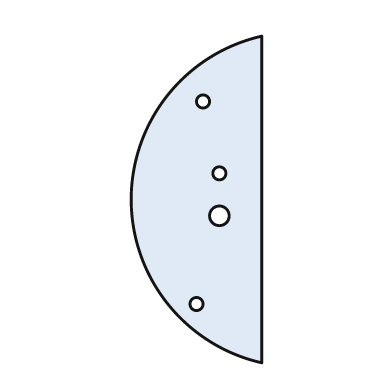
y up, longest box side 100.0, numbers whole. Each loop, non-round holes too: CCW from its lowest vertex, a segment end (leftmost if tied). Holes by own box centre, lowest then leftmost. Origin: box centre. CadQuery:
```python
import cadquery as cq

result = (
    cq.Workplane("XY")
    .moveTo(20.0, -50.0)
    .lineTo(20.0, 50.0)
    .threePointArc((-20.0, 0.0), (20.0, -50.0))
    .close()
    .moveTo(0.0, -32.0)
    .circle(2.0)
    .moveTo(7.0, -5.0)
    .circle(3.0)
    .moveTo(7.0, 8.0)
    .circle(2.0)
    .moveTo(2.0, 30.0)
    .circle(2.0)
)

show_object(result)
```